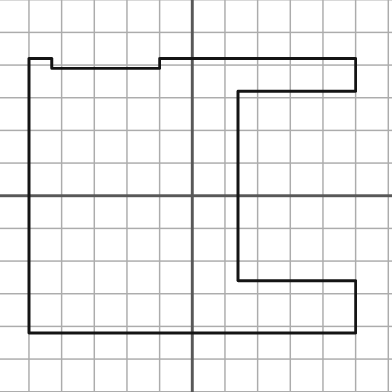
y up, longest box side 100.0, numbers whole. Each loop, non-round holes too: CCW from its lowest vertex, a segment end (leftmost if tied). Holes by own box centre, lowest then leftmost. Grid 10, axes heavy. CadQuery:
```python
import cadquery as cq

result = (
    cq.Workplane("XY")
    .moveTo(-50.0, -42.0)
    .lineTo(50.0, -42.0)
    .lineTo(50.0, -26.0)
    .lineTo(14.0, -26.0)
    .lineTo(14.0, 32.0)
    .lineTo(50.0, 32.0)
    .lineTo(50.0, 42.0)
    .lineTo(-10.0, 42.0)
    .lineTo(-10.0, 39.0)
    .lineTo(-43.0, 39.0)
    .lineTo(-43.0, 42.0)
    .lineTo(-50.0, 42.0)
    .close()
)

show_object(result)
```